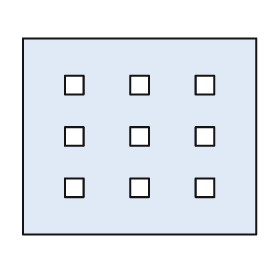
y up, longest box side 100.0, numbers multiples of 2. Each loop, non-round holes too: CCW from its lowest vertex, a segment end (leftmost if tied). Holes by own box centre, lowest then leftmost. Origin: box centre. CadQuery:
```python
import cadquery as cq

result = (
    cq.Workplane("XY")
    .moveTo(-50.0, -42.0)
    .lineTo(50.0, -42.0)
    .lineTo(50.0, 42.0)
    .lineTo(-50.0, 42.0)
    .close()
    .moveTo(-32.0, -26.0)
    .lineTo(-24.0, -26.0)
    .lineTo(-24.0, -18.0)
    .lineTo(-32.0, -18.0)
    .close()
    .moveTo(-4.0, -26.0)
    .lineTo(4.0, -26.0)
    .lineTo(4.0, -18.0)
    .lineTo(-4.0, -18.0)
    .close()
    .moveTo(24.0, -26.0)
    .lineTo(32.0, -26.0)
    .lineTo(32.0, -18.0)
    .lineTo(24.0, -18.0)
    .close()
    .moveTo(-32.0, -4.0)
    .lineTo(-24.0, -4.0)
    .lineTo(-24.0, 4.0)
    .lineTo(-32.0, 4.0)
    .close()
    .moveTo(-4.0, -4.0)
    .lineTo(4.0, -4.0)
    .lineTo(4.0, 4.0)
    .lineTo(-4.0, 4.0)
    .close()
    .moveTo(24.0, -4.0)
    .lineTo(32.0, -4.0)
    .lineTo(32.0, 4.0)
    .lineTo(24.0, 4.0)
    .close()
    .moveTo(-32.0, 18.0)
    .lineTo(-24.0, 18.0)
    .lineTo(-24.0, 26.0)
    .lineTo(-32.0, 26.0)
    .close()
    .moveTo(-4.0, 18.0)
    .lineTo(4.0, 18.0)
    .lineTo(4.0, 26.0)
    .lineTo(-4.0, 26.0)
    .close()
    .moveTo(24.0, 18.0)
    .lineTo(32.0, 18.0)
    .lineTo(32.0, 26.0)
    .lineTo(24.0, 26.0)
    .close()
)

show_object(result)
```